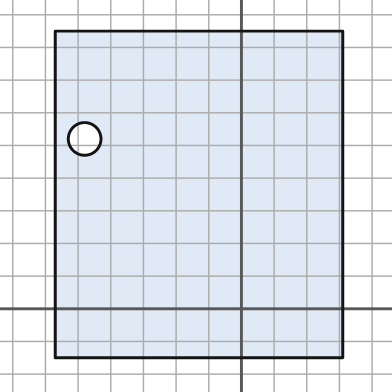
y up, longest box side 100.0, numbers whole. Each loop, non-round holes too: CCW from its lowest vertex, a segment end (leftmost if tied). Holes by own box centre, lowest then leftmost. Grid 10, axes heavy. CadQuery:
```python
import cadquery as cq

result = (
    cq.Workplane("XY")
    .moveTo(-57.0, -15.0)
    .lineTo(31.0, -15.0)
    .lineTo(31.0, 85.0)
    .lineTo(-57.0, 85.0)
    .close()
    .moveTo(-48.0, 52.0)
    .circle(5.0)
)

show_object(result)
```